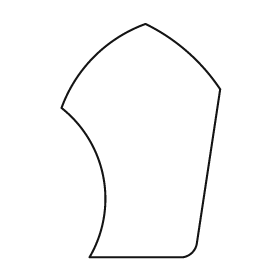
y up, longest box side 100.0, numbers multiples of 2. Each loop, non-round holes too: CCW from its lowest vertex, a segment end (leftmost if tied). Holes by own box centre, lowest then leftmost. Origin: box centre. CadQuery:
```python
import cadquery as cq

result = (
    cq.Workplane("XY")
    .moveTo(-22.0, -50.0)
    .lineTo(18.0, -50.0)
    .threePointArc((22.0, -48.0), (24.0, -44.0))
    .lineTo(34.0, 22.0)
    .threePointArc((20.0, 38.0), (2.0, 50.0))
    .threePointArc((-20.0, 36.0), (-34.0, 14.0))
    .threePointArc((-16.0, -16.0), (-22.0, -50.0))
    .close()
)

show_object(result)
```